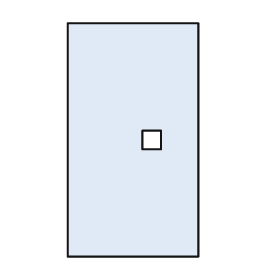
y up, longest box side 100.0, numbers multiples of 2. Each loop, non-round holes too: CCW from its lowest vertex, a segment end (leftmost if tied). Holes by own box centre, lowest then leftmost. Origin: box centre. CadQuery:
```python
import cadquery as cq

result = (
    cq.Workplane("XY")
    .moveTo(-28.0, -50.0)
    .lineTo(28.0, -50.0)
    .lineTo(28.0, 50.0)
    .lineTo(-28.0, 50.0)
    .close()
    .moveTo(4.0, -4.0)
    .lineTo(12.0, -4.0)
    .lineTo(12.0, 4.0)
    .lineTo(4.0, 4.0)
    .close()
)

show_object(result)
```